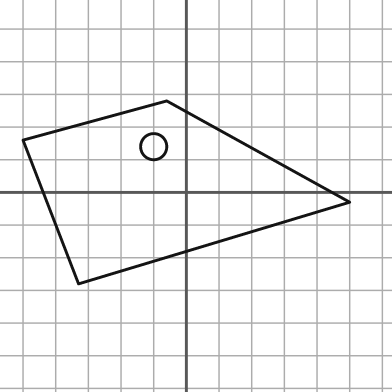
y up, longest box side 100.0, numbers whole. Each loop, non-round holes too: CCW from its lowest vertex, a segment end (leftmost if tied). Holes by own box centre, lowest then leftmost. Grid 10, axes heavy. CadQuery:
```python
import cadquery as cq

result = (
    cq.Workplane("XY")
    .moveTo(-33.0, -28.0)
    .lineTo(50.0, -3.0)
    .lineTo(-6.0, 28.0)
    .lineTo(-50.0, 16.0)
    .close()
    .moveTo(-10.0, 14.0)
    .circle(4.0)
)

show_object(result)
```